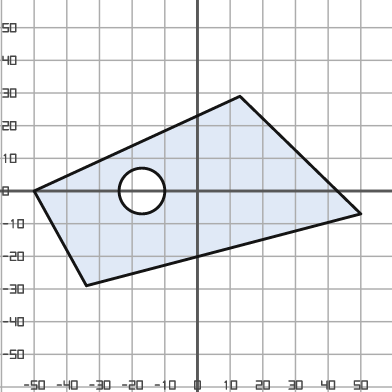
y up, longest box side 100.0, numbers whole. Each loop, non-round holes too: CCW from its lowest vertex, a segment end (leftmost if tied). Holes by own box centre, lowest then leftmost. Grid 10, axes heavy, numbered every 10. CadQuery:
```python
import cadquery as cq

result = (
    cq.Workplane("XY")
    .moveTo(-34.0, -29.0)
    .lineTo(50.0, -7.0)
    .lineTo(13.0, 29.0)
    .lineTo(-50.0, 0.0)
    .close()
    .moveTo(-17.0, 0.0)
    .circle(7.0)
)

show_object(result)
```